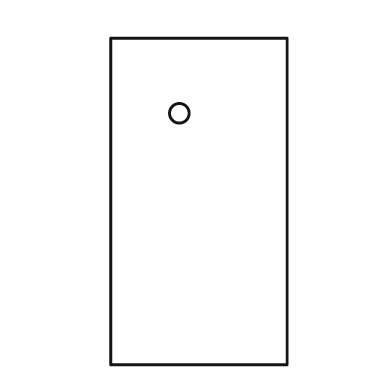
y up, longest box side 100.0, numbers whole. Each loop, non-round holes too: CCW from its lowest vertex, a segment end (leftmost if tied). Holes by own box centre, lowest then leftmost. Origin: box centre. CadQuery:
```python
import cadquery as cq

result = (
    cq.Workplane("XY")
    .moveTo(-27.0, -50.0)
    .lineTo(27.0, -50.0)
    .lineTo(27.0, 50.0)
    .lineTo(-27.0, 50.0)
    .close()
    .moveTo(-6.0, 27.0)
    .circle(3.0)
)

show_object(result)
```